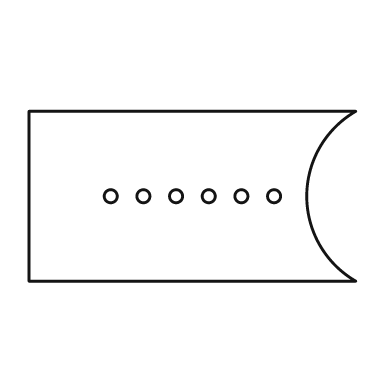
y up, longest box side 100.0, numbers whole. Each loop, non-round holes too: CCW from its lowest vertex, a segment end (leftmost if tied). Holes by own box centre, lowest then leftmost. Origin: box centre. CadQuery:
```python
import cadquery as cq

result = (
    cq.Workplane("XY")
    .moveTo(-50.0, -26.0)
    .lineTo(50.0, -26.0)
    .threePointArc((35.0, 0.0), (50.0, 26.0))
    .lineTo(-50.0, 26.0)
    .close()
    .moveTo(-25.0, 0.0)
    .circle(2.0)
    .moveTo(-15.0, 0.0)
    .circle(2.0)
    .moveTo(-5.0, 0.0)
    .circle(2.0)
    .moveTo(5.0, 0.0)
    .circle(2.0)
    .moveTo(15.0, 0.0)
    .circle(2.0)
    .moveTo(25.0, 0.0)
    .circle(2.0)
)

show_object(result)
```